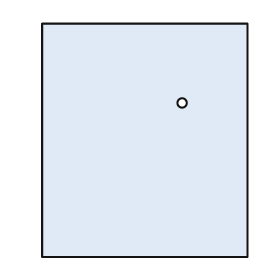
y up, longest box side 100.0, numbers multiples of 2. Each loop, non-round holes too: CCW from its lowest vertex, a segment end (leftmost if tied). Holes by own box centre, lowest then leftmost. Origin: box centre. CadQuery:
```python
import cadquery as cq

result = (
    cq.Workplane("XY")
    .moveTo(-44.0, -50.0)
    .lineTo(44.0, -50.0)
    .lineTo(44.0, 50.0)
    .lineTo(-44.0, 50.0)
    .close()
    .moveTo(16.0, 16.0)
    .circle(2.0)
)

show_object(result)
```